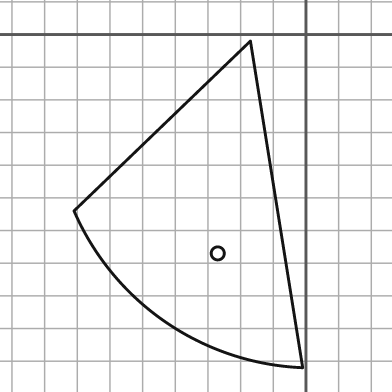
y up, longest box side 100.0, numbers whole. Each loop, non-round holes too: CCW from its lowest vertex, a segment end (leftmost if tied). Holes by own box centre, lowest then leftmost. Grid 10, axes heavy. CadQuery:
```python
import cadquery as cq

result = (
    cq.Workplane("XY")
    .moveTo(-1.0, -102.0)
    .lineTo(-17.0, -2.0)
    .lineTo(-71.0, -54.0)
    .threePointArc((-43.0, -88.0), (-1.0, -102.0))
    .close()
    .moveTo(-27.0, -67.0)
    .circle(2.0)
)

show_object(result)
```